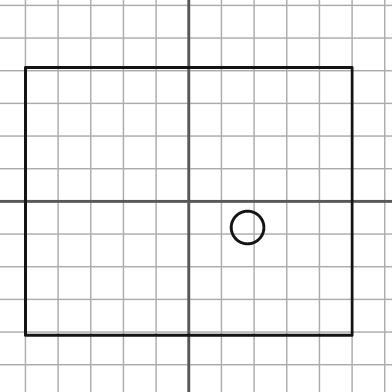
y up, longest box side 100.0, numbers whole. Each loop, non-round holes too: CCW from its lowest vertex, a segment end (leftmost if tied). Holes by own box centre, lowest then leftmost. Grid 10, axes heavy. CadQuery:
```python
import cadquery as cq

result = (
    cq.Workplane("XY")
    .moveTo(-50.0, -41.0)
    .lineTo(50.0, -41.0)
    .lineTo(50.0, 41.0)
    .lineTo(-50.0, 41.0)
    .close()
    .moveTo(18.0, -8.0)
    .circle(5.0)
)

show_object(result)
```